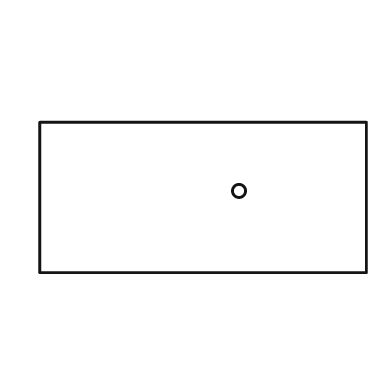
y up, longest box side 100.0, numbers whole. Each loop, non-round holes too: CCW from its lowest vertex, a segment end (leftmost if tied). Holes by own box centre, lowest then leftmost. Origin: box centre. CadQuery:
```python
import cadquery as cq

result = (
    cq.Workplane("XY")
    .moveTo(-50.0, -23.0)
    .lineTo(50.0, -23.0)
    .lineTo(50.0, 23.0)
    .lineTo(-50.0, 23.0)
    .close()
    .moveTo(11.0, 2.0)
    .circle(2.0)
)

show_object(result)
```